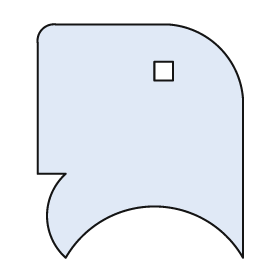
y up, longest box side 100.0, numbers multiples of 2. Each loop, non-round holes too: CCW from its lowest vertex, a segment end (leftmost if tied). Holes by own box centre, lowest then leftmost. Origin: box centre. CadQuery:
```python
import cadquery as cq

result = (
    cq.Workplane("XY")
    .moveTo(-32.0, -50.0)
    .threePointArc((6.0, -28.0), (44.0, -50.0))
    .lineTo(44.0, 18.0)
    .threePointArc((34.0, 40.0), (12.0, 50.0))
    .lineTo(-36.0, 50.0)
    .threePointArc((-42.0, 48.0), (-44.0, 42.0))
    .lineTo(-44.0, -14.0)
    .lineTo(-32.0, -14.0)
    .threePointArc((-40.0, -32.0), (-32.0, -50.0))
    .close()
    .moveTo(6.0, 26.0)
    .lineTo(14.0, 26.0)
    .lineTo(14.0, 34.0)
    .lineTo(6.0, 34.0)
    .close()
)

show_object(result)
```